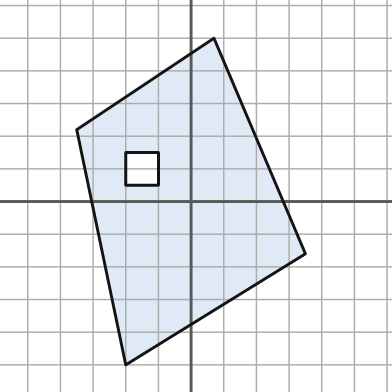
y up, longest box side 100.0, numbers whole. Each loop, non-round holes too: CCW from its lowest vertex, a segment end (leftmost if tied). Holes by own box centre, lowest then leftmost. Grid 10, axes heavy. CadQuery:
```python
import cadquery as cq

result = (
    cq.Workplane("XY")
    .moveTo(-20.0, -50.0)
    .lineTo(35.0, -16.0)
    .lineTo(7.0, 50.0)
    .lineTo(-35.0, 22.0)
    .close()
    .moveTo(-20.0, 5.0)
    .lineTo(-10.0, 5.0)
    .lineTo(-10.0, 15.0)
    .lineTo(-20.0, 15.0)
    .close()
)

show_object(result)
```